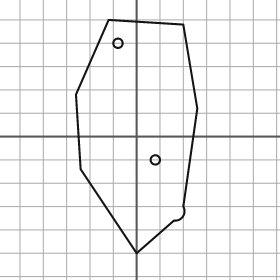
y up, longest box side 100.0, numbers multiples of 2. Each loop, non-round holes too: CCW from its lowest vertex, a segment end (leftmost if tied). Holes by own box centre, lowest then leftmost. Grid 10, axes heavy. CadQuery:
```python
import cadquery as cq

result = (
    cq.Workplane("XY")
    .moveTo(0.0, -50.0)
    .lineTo(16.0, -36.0)
    .threePointArc((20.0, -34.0), (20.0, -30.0))
    .lineTo(26.0, 12.0)
    .lineTo(20.0, 48.0)
    .lineTo(-12.0, 50.0)
    .lineTo(-26.0, 18.0)
    .lineTo(-24.0, -14.0)
    .close()
    .moveTo(8.0, -10.0)
    .circle(2.0)
    .moveTo(-8.0, 40.0)
    .circle(2.0)
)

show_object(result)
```